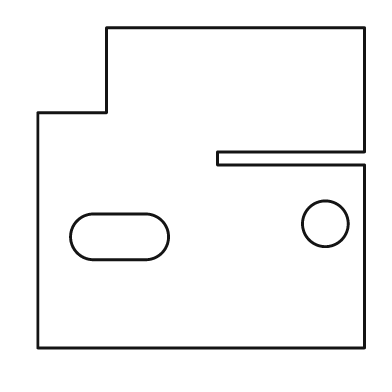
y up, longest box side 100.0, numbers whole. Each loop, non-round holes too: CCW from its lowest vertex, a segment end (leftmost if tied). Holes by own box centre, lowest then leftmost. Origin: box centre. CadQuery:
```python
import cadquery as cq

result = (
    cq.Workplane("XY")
    .moveTo(-50.0, -49.0)
    .lineTo(50.0, -49.0)
    .lineTo(50.0, 7.0)
    .lineTo(5.0, 7.0)
    .lineTo(5.0, 11.0)
    .lineTo(50.0, 11.0)
    .lineTo(50.0, 49.0)
    .lineTo(-29.0, 49.0)
    .lineTo(-29.0, 23.0)
    .lineTo(-50.0, 23.0)
    .close()
    .moveTo(-33.0, -22.0)
    .lineTo(-17.0, -22.0)
    .threePointArc((-10.0, -15.0), (-17.0, -8.0))
    .lineTo(-33.0, -8.0)
    .threePointArc((-40.0, -15.0), (-33.0, -22.0))
    .close()
    .moveTo(38.0, -11.0)
    .circle(7.0)
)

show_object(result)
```